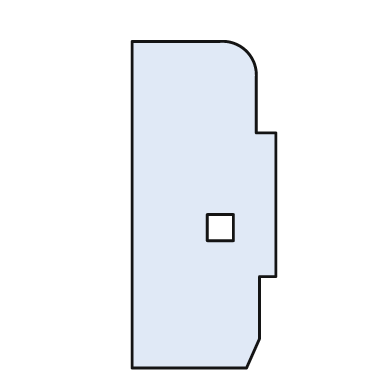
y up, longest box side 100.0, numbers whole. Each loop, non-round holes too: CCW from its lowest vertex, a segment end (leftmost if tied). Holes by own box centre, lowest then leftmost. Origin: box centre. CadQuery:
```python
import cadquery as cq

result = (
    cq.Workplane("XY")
    .moveTo(-22.0, -50.0)
    .lineTo(13.0, -50.0)
    .lineTo(17.0, -41.0)
    .lineTo(17.0, -22.0)
    .lineTo(22.0, -22.0)
    .lineTo(22.0, 22.0)
    .lineTo(16.0, 22.0)
    .lineTo(16.0, 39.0)
    .threePointArc((13.0, 47.0), (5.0, 50.0))
    .lineTo(-22.0, 50.0)
    .close()
    .moveTo(1.0, -11.0)
    .lineTo(9.0, -11.0)
    .lineTo(9.0, -3.0)
    .lineTo(1.0, -3.0)
    .close()
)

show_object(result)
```